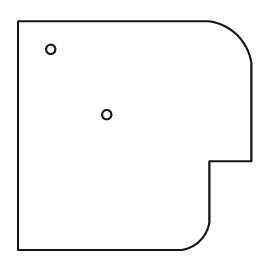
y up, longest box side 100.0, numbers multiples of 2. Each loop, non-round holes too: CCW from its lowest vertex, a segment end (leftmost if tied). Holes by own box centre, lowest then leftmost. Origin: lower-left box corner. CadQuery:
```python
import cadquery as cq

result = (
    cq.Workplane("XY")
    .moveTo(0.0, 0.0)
    .lineTo(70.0, 0.0)
    .threePointArc((78.0, 4.0), (82.0, 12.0))
    .lineTo(82.0, 38.0)
    .lineTo(100.0, 38.0)
    .lineTo(100.0, 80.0)
    .threePointArc((94.0, 92.0), (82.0, 98.0))
    .lineTo(0.0, 98.0)
    .close()
    .moveTo(38.0, 58.0)
    .circle(2.0)
    .moveTo(14.0, 86.0)
    .circle(2.0)
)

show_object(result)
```